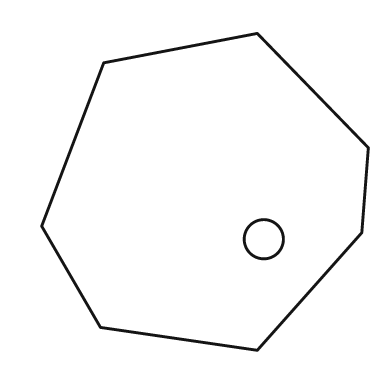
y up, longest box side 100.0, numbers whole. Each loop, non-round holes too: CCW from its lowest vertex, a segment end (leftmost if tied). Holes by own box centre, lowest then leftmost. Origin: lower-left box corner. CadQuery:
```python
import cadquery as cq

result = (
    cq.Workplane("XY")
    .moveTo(66.0, 0.0)
    .lineTo(98.0, 36.0)
    .lineTo(100.0, 62.0)
    .lineTo(66.0, 97.0)
    .lineTo(19.0, 88.0)
    .lineTo(0.0, 38.0)
    .lineTo(18.0, 7.0)
    .close()
    .moveTo(68.0, 34.0)
    .circle(6.0)
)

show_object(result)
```